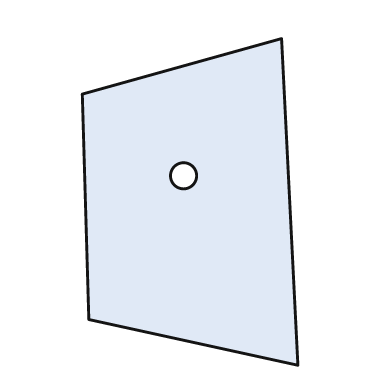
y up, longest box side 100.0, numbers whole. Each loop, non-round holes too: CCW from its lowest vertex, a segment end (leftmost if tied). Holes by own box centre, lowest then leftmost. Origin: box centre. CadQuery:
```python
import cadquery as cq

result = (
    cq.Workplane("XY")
    .moveTo(33.0, -50.0)
    .lineTo(28.0, 50.0)
    .lineTo(-33.0, 33.0)
    .lineTo(-31.0, -36.0)
    .close()
    .moveTo(-2.0, 8.0)
    .circle(4.0)
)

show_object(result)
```